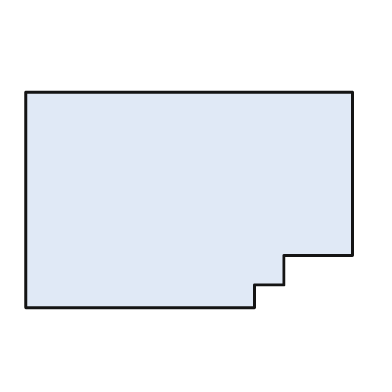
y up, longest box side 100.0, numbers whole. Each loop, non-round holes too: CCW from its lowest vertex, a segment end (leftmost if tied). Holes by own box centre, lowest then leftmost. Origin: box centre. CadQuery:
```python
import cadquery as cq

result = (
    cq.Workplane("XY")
    .moveTo(-50.0, -33.0)
    .lineTo(20.0, -33.0)
    .lineTo(20.0, -26.0)
    .lineTo(29.0, -26.0)
    .lineTo(29.0, -17.0)
    .lineTo(50.0, -17.0)
    .lineTo(50.0, 33.0)
    .lineTo(-50.0, 33.0)
    .close()
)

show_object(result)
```